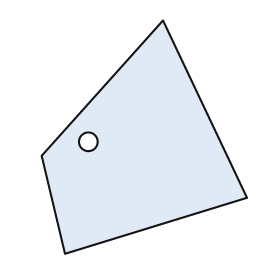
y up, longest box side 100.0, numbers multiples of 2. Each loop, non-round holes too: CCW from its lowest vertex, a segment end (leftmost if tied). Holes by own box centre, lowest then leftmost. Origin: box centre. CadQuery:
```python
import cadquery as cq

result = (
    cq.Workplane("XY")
    .moveTo(-34.0, -50.0)
    .lineTo(44.0, -26.0)
    .lineTo(8.0, 50.0)
    .lineTo(-44.0, -8.0)
    .close()
    .moveTo(-24.0, -2.0)
    .circle(4.0)
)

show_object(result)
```